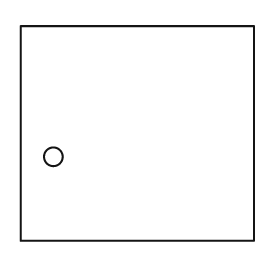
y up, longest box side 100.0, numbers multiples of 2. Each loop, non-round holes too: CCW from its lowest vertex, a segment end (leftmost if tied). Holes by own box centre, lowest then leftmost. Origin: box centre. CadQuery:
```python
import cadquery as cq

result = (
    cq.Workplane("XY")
    .moveTo(-50.0, -46.0)
    .lineTo(50.0, -46.0)
    .lineTo(50.0, 46.0)
    .lineTo(-50.0, 46.0)
    .close()
    .moveTo(-36.0, -10.0)
    .circle(4.0)
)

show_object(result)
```